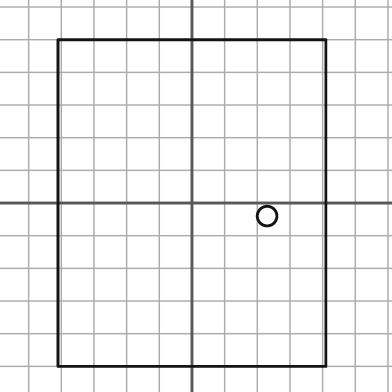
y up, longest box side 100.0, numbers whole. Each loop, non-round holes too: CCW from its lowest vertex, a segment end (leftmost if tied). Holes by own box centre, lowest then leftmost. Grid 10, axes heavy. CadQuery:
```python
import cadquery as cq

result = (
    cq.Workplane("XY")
    .moveTo(-41.0, -50.0)
    .lineTo(41.0, -50.0)
    .lineTo(41.0, 50.0)
    .lineTo(-41.0, 50.0)
    .close()
    .moveTo(23.0, -4.0)
    .circle(3.0)
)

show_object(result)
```